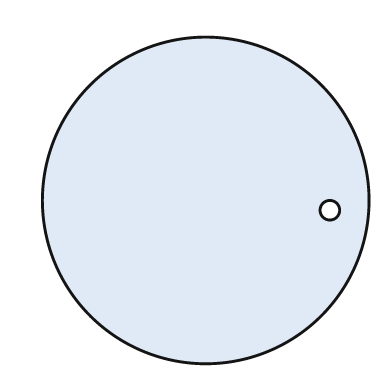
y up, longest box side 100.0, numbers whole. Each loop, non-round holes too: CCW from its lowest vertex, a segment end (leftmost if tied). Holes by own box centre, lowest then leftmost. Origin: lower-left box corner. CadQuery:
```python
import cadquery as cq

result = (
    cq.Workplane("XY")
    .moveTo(50.0, 50.0)
    .circle(50.0)
    .moveTo(88.0, 47.0)
    .circle(3.0)
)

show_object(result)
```